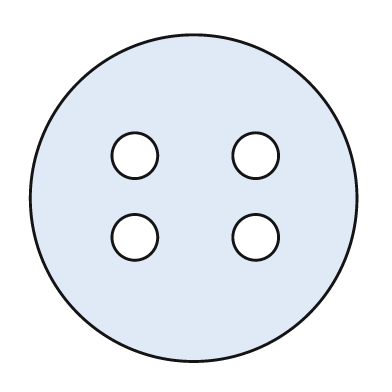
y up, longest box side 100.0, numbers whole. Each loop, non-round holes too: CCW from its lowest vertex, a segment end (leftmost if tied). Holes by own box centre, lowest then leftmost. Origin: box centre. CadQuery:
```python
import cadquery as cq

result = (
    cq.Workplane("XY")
    .moveTo(0.0, 0.0)
    .circle(50.0)
    .moveTo(-18.0, -12.0)
    .circle(7.0)
    .moveTo(19.0, -12.0)
    .circle(7.0)
    .moveTo(-18.0, 13.0)
    .circle(7.0)
    .moveTo(19.0, 13.0)
    .circle(7.0)
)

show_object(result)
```